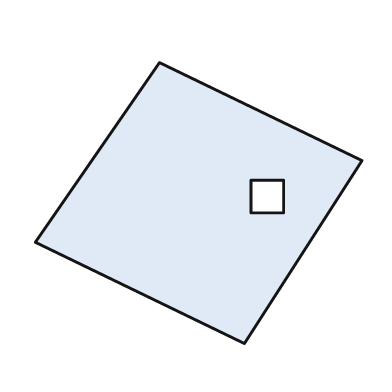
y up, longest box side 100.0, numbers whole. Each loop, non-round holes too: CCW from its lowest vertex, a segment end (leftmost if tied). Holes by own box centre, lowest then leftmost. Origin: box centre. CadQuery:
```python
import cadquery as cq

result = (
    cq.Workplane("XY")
    .moveTo(14.0, -43.0)
    .lineTo(50.0, 13.0)
    .lineTo(-12.0, 43.0)
    .lineTo(-50.0, -12.0)
    .close()
    .moveTo(16.0, -3.0)
    .lineTo(26.0, -3.0)
    .lineTo(26.0, 7.0)
    .lineTo(16.0, 7.0)
    .close()
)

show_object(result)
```